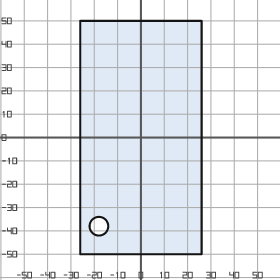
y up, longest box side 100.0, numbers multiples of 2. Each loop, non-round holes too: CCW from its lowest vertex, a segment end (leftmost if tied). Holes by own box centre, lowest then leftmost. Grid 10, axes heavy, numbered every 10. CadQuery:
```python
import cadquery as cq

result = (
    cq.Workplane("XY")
    .moveTo(-26.0, -50.0)
    .lineTo(26.0, -50.0)
    .lineTo(26.0, 50.0)
    .lineTo(-26.0, 50.0)
    .close()
    .moveTo(-18.0, -38.0)
    .circle(4.0)
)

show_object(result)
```